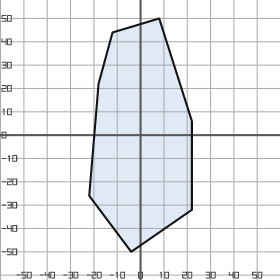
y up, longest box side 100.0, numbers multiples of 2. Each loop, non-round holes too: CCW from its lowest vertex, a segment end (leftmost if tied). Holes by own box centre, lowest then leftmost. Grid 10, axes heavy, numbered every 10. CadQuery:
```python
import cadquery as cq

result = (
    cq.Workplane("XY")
    .moveTo(-4.0, -50.0)
    .lineTo(22.0, -32.0)
    .lineTo(22.0, 6.0)
    .lineTo(8.0, 50.0)
    .lineTo(-12.0, 44.0)
    .lineTo(-18.0, 22.0)
    .lineTo(-22.0, -26.0)
    .close()
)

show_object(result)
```